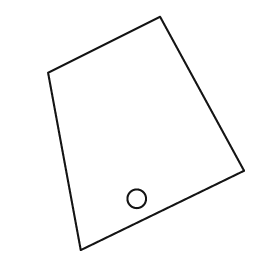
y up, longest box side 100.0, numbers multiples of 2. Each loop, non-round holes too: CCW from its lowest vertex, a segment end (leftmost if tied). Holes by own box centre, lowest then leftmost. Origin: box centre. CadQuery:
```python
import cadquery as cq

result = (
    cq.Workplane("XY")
    .moveTo(-28.0, -50.0)
    .lineTo(42.0, -16.0)
    .lineTo(6.0, 50.0)
    .lineTo(-42.0, 26.0)
    .close()
    .moveTo(-4.0, -28.0)
    .circle(4.0)
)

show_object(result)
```